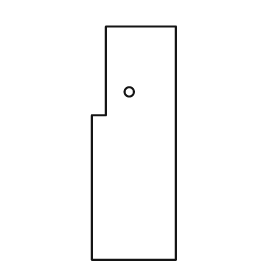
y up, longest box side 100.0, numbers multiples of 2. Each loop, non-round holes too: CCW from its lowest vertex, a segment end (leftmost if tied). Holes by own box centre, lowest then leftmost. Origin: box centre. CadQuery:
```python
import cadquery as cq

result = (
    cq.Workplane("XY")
    .moveTo(-18.0, -50.0)
    .lineTo(18.0, -50.0)
    .lineTo(18.0, 50.0)
    .lineTo(-12.0, 50.0)
    .lineTo(-12.0, 12.0)
    .lineTo(-18.0, 12.0)
    .close()
    .moveTo(-2.0, 22.0)
    .circle(2.0)
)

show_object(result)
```